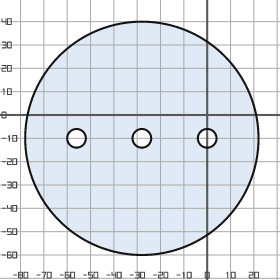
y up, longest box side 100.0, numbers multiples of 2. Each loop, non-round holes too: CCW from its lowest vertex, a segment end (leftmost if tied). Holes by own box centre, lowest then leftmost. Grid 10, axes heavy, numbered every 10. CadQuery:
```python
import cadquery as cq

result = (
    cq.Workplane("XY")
    .moveTo(-28.0, -10.0)
    .circle(50.0)
    .moveTo(-56.0, -10.0)
    .circle(4.0)
    .moveTo(-28.0, -10.0)
    .circle(4.0)
    .moveTo(0.0, -10.0)
    .circle(4.0)
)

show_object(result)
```